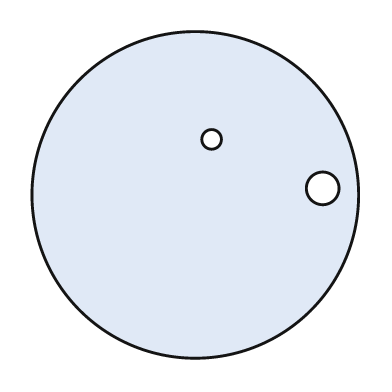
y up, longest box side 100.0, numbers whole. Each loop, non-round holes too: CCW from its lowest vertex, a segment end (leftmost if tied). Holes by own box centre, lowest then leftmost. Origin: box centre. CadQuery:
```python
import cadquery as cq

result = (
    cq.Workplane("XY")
    .moveTo(0.0, 0.0)
    .circle(50.0)
    .moveTo(39.0, 2.0)
    .circle(5.0)
    .moveTo(5.0, 17.0)
    .circle(3.0)
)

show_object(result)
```